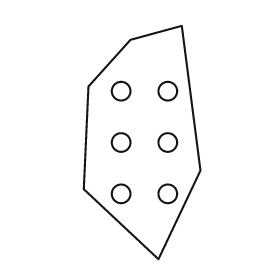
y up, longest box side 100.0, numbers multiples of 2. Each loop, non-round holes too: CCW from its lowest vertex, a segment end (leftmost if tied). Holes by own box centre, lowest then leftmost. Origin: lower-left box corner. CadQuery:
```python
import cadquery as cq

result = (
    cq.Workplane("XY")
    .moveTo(32.0, 0.0)
    .lineTo(50.0, 38.0)
    .lineTo(42.0, 100.0)
    .lineTo(20.0, 94.0)
    .lineTo(2.0, 74.0)
    .lineTo(0.0, 30.0)
    .close()
    .moveTo(16.0, 28.0)
    .circle(4.0)
    .moveTo(36.0, 28.0)
    .circle(4.0)
    .moveTo(16.0, 50.0)
    .circle(4.0)
    .moveTo(36.0, 50.0)
    .circle(4.0)
    .moveTo(16.0, 72.0)
    .circle(4.0)
    .moveTo(36.0, 72.0)
    .circle(4.0)
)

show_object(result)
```